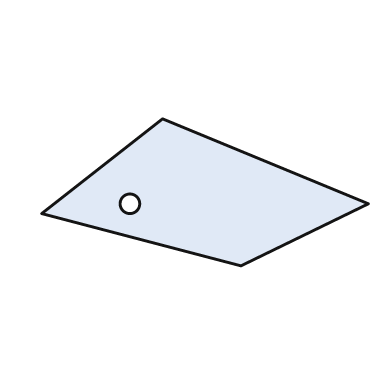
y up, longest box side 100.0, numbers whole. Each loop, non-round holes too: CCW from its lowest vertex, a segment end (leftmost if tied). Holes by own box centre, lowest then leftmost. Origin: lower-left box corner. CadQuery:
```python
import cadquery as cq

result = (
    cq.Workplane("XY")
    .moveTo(61.0, 0.0)
    .lineTo(100.0, 19.0)
    .lineTo(37.0, 45.0)
    .lineTo(0.0, 16.0)
    .close()
    .moveTo(27.0, 19.0)
    .circle(3.0)
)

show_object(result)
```